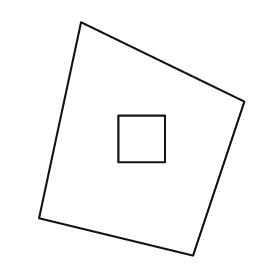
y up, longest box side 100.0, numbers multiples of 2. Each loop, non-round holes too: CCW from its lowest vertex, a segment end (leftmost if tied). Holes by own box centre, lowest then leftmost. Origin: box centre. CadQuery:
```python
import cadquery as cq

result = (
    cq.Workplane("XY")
    .moveTo(22.0, -50.0)
    .lineTo(44.0, 16.0)
    .lineTo(-26.0, 50.0)
    .lineTo(-44.0, -34.0)
    .close()
    .moveTo(-10.0, -10.0)
    .lineTo(10.0, -10.0)
    .lineTo(10.0, 10.0)
    .lineTo(-10.0, 10.0)
    .close()
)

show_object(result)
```